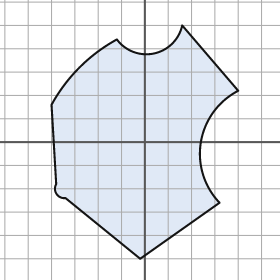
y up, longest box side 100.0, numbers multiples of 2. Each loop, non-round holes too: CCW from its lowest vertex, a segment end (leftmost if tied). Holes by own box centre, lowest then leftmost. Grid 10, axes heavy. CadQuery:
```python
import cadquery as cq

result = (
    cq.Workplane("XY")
    .moveTo(-2.0, -50.0)
    .lineTo(32.0, -26.0)
    .threePointArc((24.0, 0.0), (40.0, 22.0))
    .lineTo(16.0, 50.0)
    .threePointArc((4.0, 38.0), (-12.0, 44.0))
    .threePointArc((-28.0, 32.0), (-40.0, 16.0))
    .lineTo(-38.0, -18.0)
    .threePointArc((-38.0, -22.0), (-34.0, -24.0))
    .close()
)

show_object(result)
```